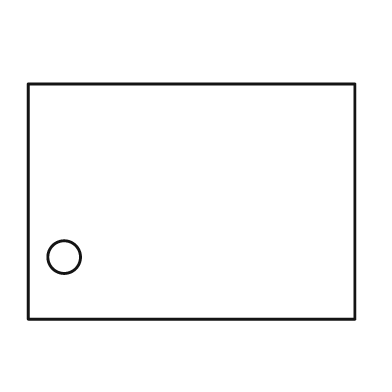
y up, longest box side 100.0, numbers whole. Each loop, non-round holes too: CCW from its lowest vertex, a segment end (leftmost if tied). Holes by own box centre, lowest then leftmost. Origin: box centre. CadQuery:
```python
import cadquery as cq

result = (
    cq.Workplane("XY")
    .moveTo(-50.0, -36.0)
    .lineTo(50.0, -36.0)
    .lineTo(50.0, 36.0)
    .lineTo(-50.0, 36.0)
    .close()
    .moveTo(-39.0, -17.0)
    .circle(5.0)
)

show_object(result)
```